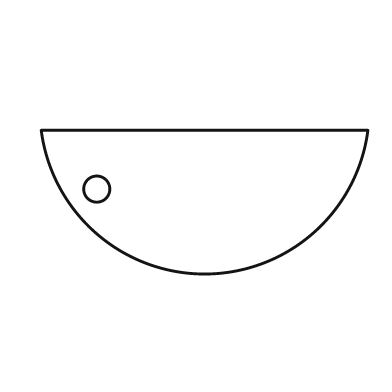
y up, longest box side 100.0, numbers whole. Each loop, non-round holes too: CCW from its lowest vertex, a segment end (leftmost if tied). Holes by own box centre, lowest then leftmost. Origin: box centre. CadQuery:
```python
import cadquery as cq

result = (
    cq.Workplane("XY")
    .moveTo(-50.0, 22.0)
    .threePointArc((0.0, -22.0), (50.0, 22.0))
    .close()
    .moveTo(-33.0, 4.0)
    .circle(4.0)
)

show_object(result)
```